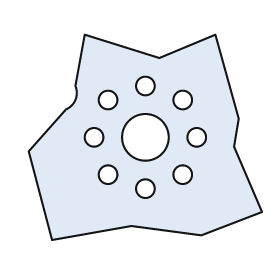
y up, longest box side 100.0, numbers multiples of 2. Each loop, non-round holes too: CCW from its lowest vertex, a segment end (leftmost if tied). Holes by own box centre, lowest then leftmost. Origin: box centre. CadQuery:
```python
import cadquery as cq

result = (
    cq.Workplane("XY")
    .moveTo(-40.0, -44.0)
    .lineTo(-6.0, -38.0)
    .lineTo(24.0, -42.0)
    .lineTo(50.0, -32.0)
    .lineTo(38.0, -4.0)
    .lineTo(40.0, 8.0)
    .lineTo(30.0, 44.0)
    .lineTo(6.0, 34.0)
    .lineTo(-26.0, 44.0)
    .lineTo(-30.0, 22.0)
    .threePointArc((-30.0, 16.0), (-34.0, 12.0))
    .lineTo(-50.0, -6.0)
    .close()
    .moveTo(0.0, -22.0)
    .circle(4.0)
    .moveTo(-16.0, -16.0)
    .circle(4.0)
    .moveTo(16.0, -16.0)
    .circle(4.0)
    .moveTo(-22.0, 0.0)
    .circle(4.0)
    .moveTo(0.0, 0.0)
    .circle(10.0)
    .moveTo(22.0, 0.0)
    .circle(4.0)
    .moveTo(-16.0, 16.0)
    .circle(4.0)
    .moveTo(16.0, 16.0)
    .circle(4.0)
    .moveTo(0.0, 22.0)
    .circle(4.0)
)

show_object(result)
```